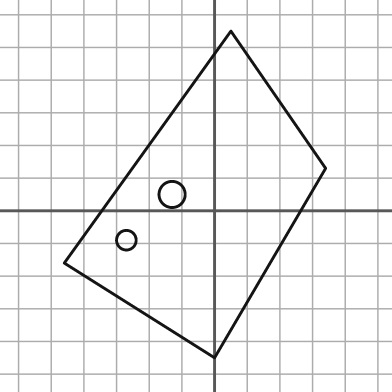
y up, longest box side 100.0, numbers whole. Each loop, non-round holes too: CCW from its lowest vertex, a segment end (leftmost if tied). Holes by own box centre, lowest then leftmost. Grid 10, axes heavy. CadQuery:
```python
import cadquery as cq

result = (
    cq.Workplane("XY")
    .moveTo(0.0, -45.0)
    .lineTo(34.0, 13.0)
    .lineTo(5.0, 55.0)
    .lineTo(-46.0, -16.0)
    .close()
    .moveTo(-27.0, -9.0)
    .circle(3.0)
    .moveTo(-13.0, 5.0)
    .circle(4.0)
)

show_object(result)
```